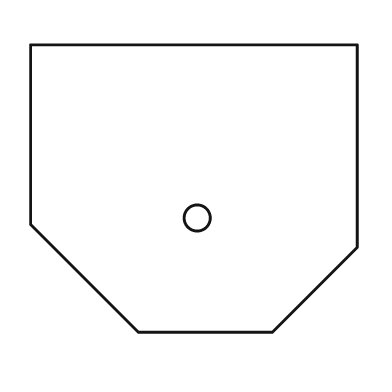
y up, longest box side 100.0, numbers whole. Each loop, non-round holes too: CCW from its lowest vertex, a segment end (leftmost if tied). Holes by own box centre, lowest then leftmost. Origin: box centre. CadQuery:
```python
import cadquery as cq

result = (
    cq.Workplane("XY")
    .moveTo(-17.0, -44.0)
    .lineTo(24.0, -44.0)
    .lineTo(50.0, -18.0)
    .lineTo(50.0, 44.0)
    .lineTo(-50.0, 44.0)
    .lineTo(-50.0, -11.0)
    .close()
    .moveTo(1.0, -9.0)
    .circle(4.0)
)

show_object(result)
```